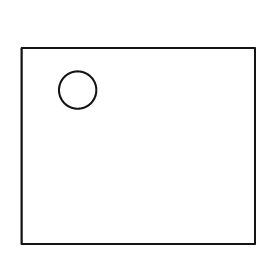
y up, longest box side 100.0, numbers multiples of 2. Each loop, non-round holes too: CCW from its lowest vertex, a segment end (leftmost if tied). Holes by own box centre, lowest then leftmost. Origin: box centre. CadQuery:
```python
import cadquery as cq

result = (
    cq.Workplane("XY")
    .moveTo(-50.0, -42.0)
    .lineTo(50.0, -42.0)
    .lineTo(50.0, 42.0)
    .lineTo(-50.0, 42.0)
    .close()
    .moveTo(-26.0, 24.0)
    .circle(8.0)
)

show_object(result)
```